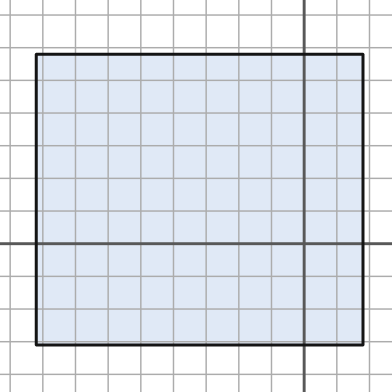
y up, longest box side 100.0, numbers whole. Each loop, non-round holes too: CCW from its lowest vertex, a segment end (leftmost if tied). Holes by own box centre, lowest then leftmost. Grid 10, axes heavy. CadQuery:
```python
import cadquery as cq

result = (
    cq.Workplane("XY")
    .moveTo(-82.0, -31.0)
    .lineTo(18.0, -31.0)
    .lineTo(18.0, 58.0)
    .lineTo(-82.0, 58.0)
    .close()
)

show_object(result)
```